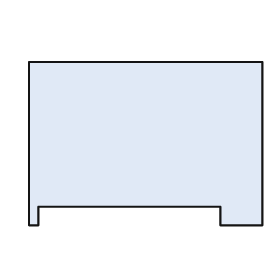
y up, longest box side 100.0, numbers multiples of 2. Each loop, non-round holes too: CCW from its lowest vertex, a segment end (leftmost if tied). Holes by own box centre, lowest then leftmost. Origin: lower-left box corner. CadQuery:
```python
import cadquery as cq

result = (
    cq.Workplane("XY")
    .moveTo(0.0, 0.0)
    .lineTo(4.0, 0.0)
    .lineTo(4.0, 8.0)
    .lineTo(82.0, 8.0)
    .lineTo(82.0, 0.0)
    .lineTo(100.0, 0.0)
    .lineTo(100.0, 70.0)
    .lineTo(0.0, 70.0)
    .close()
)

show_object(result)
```